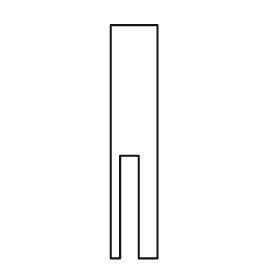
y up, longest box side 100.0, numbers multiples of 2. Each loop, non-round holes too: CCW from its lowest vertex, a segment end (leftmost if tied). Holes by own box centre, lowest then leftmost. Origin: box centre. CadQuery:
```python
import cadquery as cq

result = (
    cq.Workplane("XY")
    .moveTo(-10.0, -50.0)
    .lineTo(-6.0, -50.0)
    .lineTo(-6.0, -6.0)
    .lineTo(2.0, -6.0)
    .lineTo(2.0, -50.0)
    .lineTo(10.0, -50.0)
    .lineTo(10.0, 50.0)
    .lineTo(-10.0, 50.0)
    .close()
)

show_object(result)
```